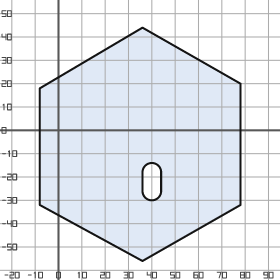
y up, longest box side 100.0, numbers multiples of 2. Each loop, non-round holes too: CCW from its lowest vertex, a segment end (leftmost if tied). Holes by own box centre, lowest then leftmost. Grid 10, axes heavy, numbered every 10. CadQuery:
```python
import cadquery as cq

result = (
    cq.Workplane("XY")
    .moveTo(36.0, -56.0)
    .lineTo(78.0, -32.0)
    .lineTo(78.0, 20.0)
    .lineTo(36.0, 44.0)
    .lineTo(-8.0, 18.0)
    .lineTo(-8.0, -32.0)
    .close()
    .moveTo(36.0, -26.0)
    .threePointArc((40.0, -30.0), (44.0, -26.0))
    .lineTo(44.0, -18.0)
    .threePointArc((40.0, -14.0), (36.0, -18.0))
    .close()
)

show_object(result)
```